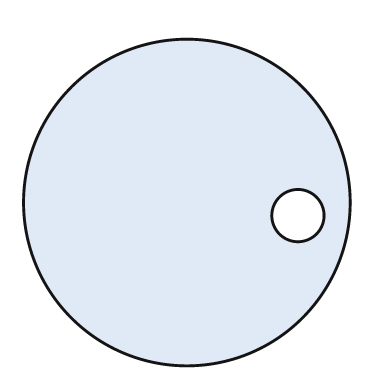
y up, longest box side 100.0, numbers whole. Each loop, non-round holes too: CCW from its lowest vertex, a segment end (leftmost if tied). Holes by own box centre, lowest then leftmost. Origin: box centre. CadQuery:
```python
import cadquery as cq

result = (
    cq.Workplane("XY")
    .moveTo(0.0, 0.0)
    .circle(50.0)
    .moveTo(34.0, -4.0)
    .circle(8.0)
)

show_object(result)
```